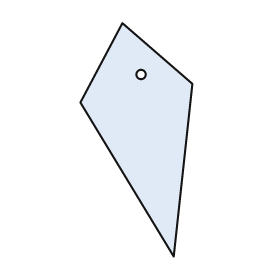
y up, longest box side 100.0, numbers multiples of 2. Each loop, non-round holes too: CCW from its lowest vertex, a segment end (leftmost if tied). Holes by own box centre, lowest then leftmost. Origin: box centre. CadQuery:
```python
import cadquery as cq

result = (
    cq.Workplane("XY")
    .moveTo(16.0, -50.0)
    .lineTo(24.0, 24.0)
    .lineTo(-6.0, 50.0)
    .lineTo(-24.0, 16.0)
    .close()
    .moveTo(2.0, 28.0)
    .circle(2.0)
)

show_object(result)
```